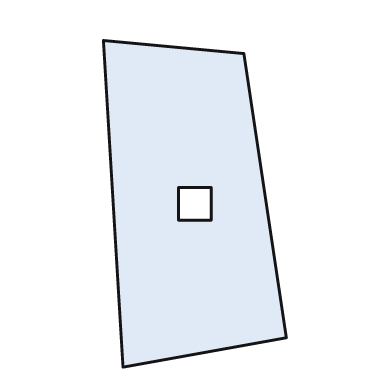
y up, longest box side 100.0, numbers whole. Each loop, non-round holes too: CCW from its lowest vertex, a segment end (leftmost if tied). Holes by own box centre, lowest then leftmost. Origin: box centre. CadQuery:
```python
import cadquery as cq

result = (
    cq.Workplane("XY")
    .moveTo(-22.0, -50.0)
    .lineTo(28.0, -41.0)
    .lineTo(15.0, 46.0)
    .lineTo(-28.0, 50.0)
    .close()
    .moveTo(-5.0, -5.0)
    .lineTo(5.0, -5.0)
    .lineTo(5.0, 5.0)
    .lineTo(-5.0, 5.0)
    .close()
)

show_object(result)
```